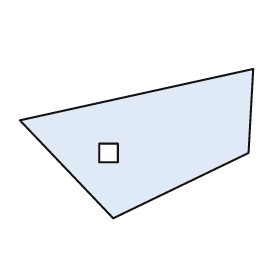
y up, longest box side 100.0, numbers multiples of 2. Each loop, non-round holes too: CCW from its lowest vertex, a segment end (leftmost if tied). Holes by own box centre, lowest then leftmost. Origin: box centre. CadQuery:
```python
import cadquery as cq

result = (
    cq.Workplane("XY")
    .moveTo(-10.0, -32.0)
    .lineTo(48.0, -4.0)
    .lineTo(50.0, 32.0)
    .lineTo(-50.0, 10.0)
    .close()
    .moveTo(-16.0, -8.0)
    .lineTo(-8.0, -8.0)
    .lineTo(-8.0, 0.0)
    .lineTo(-16.0, 0.0)
    .close()
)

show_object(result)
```